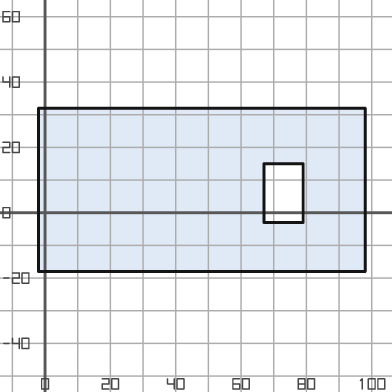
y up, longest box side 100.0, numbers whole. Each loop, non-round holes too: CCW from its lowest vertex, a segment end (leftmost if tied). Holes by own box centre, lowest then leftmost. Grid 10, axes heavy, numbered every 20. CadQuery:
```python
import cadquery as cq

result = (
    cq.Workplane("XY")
    .moveTo(-2.0, -18.0)
    .lineTo(98.0, -18.0)
    .lineTo(98.0, 32.0)
    .lineTo(-2.0, 32.0)
    .close()
    .moveTo(67.0, -3.0)
    .lineTo(79.0, -3.0)
    .lineTo(79.0, 15.0)
    .lineTo(67.0, 15.0)
    .close()
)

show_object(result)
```